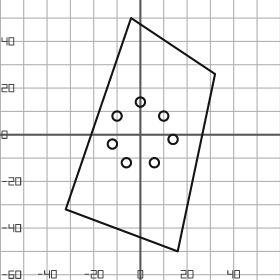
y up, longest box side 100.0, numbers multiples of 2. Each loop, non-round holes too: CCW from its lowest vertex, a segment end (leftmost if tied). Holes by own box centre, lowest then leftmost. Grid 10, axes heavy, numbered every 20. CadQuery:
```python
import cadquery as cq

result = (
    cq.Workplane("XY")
    .moveTo(16.0, -50.0)
    .lineTo(32.0, 26.0)
    .lineTo(-4.0, 50.0)
    .lineTo(-32.0, -32.0)
    .close()
    .moveTo(-6.0, -12.0)
    .circle(2.0)
    .moveTo(6.0, -12.0)
    .circle(2.0)
    .moveTo(-12.0, -4.0)
    .circle(2.0)
    .moveTo(14.0, -2.0)
    .circle(2.0)
    .moveTo(-10.0, 8.0)
    .circle(2.0)
    .moveTo(10.0, 8.0)
    .circle(2.0)
    .moveTo(0.0, 14.0)
    .circle(2.0)
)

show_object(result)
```